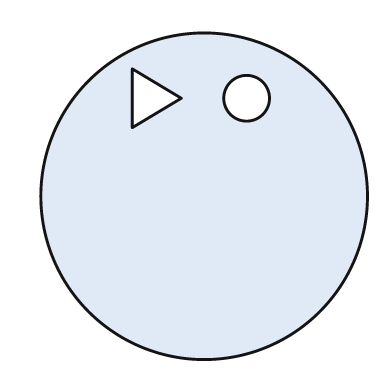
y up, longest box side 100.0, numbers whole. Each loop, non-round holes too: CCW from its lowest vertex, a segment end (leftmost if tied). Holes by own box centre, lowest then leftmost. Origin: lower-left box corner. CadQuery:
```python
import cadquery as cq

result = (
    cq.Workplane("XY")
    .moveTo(50.0, 50.0)
    .circle(50.0)
    .moveTo(28.0, 71.0)
    .lineTo(43.0, 80.0)
    .lineTo(28.0, 89.0)
    .close()
    .moveTo(63.0, 80.0)
    .circle(7.0)
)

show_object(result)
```